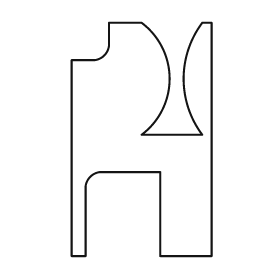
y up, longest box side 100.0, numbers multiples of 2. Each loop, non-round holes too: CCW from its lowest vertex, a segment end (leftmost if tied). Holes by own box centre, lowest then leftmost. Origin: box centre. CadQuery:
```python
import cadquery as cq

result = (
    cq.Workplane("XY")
    .moveTo(-30.0, -50.0)
    .lineTo(-24.0, -50.0)
    .lineTo(-24.0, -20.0)
    .threePointArc((-22.0, -16.0), (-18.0, -14.0))
    .lineTo(8.0, -14.0)
    .lineTo(8.0, -50.0)
    .lineTo(30.0, -50.0)
    .lineTo(30.0, 50.0)
    .lineTo(26.0, 50.0)
    .threePointArc((18.0, 26.0), (26.0, 2.0))
    .lineTo(0.0, 2.0)
    .threePointArc((12.0, 26.0), (0.0, 50.0))
    .lineTo(-14.0, 50.0)
    .lineTo(-14.0, 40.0)
    .threePointArc((-16.0, 36.0), (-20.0, 34.0))
    .lineTo(-30.0, 34.0)
    .close()
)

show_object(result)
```